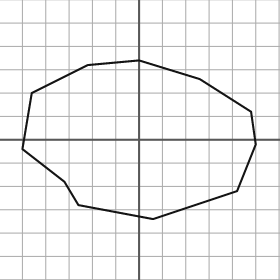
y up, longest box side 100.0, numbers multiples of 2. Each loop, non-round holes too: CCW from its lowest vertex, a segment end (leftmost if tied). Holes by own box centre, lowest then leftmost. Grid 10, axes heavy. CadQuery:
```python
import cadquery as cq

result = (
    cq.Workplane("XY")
    .moveTo(6.0, -34.0)
    .lineTo(42.0, -22.0)
    .lineTo(50.0, -2.0)
    .lineTo(48.0, 12.0)
    .lineTo(26.0, 26.0)
    .lineTo(0.0, 34.0)
    .lineTo(-22.0, 32.0)
    .lineTo(-46.0, 20.0)
    .lineTo(-50.0, -4.0)
    .lineTo(-32.0, -18.0)
    .lineTo(-26.0, -28.0)
    .close()
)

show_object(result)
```